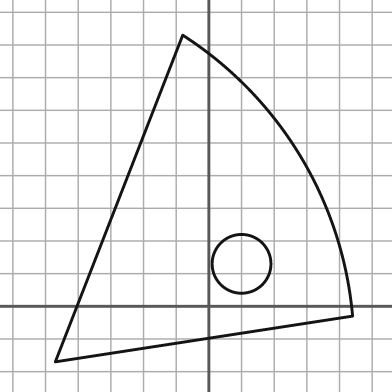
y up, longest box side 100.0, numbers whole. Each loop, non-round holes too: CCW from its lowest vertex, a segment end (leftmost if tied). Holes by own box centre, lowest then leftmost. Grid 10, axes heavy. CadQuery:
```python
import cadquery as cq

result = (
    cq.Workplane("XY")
    .moveTo(-47.0, -17.0)
    .lineTo(44.0, -3.0)
    .threePointArc((28.0, 46.0), (-8.0, 83.0))
    .close()
    .moveTo(10.0, 13.0)
    .circle(9.0)
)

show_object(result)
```